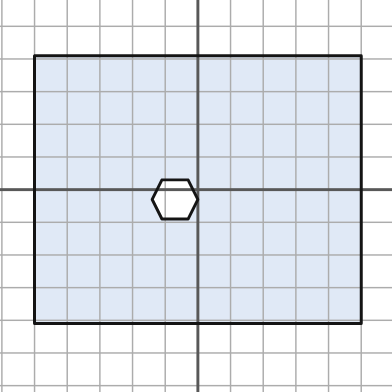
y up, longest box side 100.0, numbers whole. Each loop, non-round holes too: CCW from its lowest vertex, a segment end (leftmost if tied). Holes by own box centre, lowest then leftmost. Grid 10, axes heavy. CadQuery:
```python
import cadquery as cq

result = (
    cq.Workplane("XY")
    .moveTo(-50.0, -41.0)
    .lineTo(50.0, -41.0)
    .lineTo(50.0, 41.0)
    .lineTo(-50.0, 41.0)
    .close()
    .moveTo(-11.0, -9.0)
    .lineTo(-3.0, -9.0)
    .lineTo(0.0, -3.0)
    .lineTo(-3.0, 3.0)
    .lineTo(-11.0, 3.0)
    .lineTo(-14.0, -3.0)
    .close()
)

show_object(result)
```